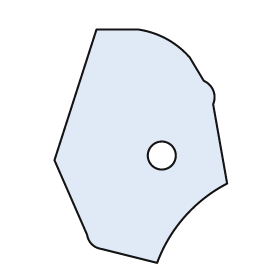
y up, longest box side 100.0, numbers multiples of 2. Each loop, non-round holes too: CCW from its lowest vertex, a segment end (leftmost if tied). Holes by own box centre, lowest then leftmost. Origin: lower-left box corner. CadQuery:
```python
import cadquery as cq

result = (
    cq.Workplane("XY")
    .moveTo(44.0, 0.0)
    .threePointArc((56.0, 20.0), (74.0, 34.0))
    .lineTo(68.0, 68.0)
    .threePointArc((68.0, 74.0), (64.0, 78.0))
    .lineTo(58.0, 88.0)
    .threePointArc((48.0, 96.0), (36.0, 100.0))
    .lineTo(18.0, 100.0)
    .lineTo(0.0, 44.0)
    .lineTo(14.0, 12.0)
    .threePointArc((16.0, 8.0), (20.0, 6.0))
    .close()
    .moveTo(46.0, 46.0)
    .circle(6.0)
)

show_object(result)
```